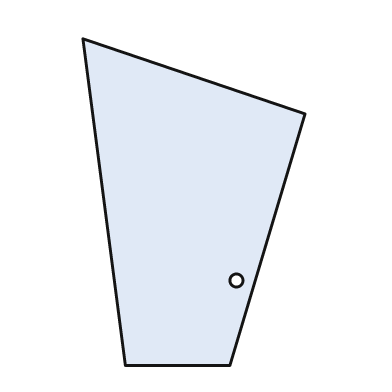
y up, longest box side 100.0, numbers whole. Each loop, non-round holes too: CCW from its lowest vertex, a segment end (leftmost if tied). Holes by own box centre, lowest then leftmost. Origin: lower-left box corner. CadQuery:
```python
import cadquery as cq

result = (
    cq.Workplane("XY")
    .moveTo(13.0, 0.0)
    .lineTo(45.0, 0.0)
    .lineTo(68.0, 77.0)
    .lineTo(0.0, 100.0)
    .close()
    .moveTo(47.0, 26.0)
    .circle(2.0)
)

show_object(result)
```